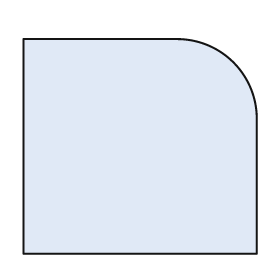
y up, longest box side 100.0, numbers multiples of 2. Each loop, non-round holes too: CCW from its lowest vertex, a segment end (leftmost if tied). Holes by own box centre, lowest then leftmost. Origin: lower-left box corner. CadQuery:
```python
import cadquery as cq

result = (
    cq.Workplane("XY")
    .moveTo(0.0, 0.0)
    .lineTo(100.0, 0.0)
    .lineTo(100.0, 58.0)
    .threePointArc((90.0, 82.0), (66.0, 92.0))
    .lineTo(0.0, 92.0)
    .close()
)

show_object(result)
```